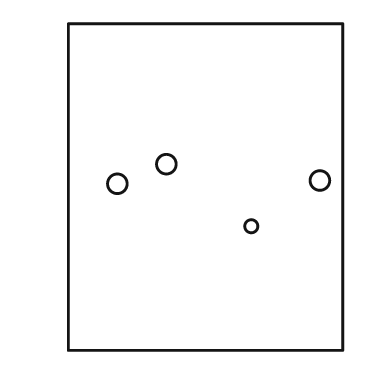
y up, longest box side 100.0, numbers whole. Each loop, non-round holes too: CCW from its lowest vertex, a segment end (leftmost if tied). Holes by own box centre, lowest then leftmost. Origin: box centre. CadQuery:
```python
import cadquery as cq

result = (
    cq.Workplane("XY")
    .moveTo(-42.0, -50.0)
    .lineTo(42.0, -50.0)
    .lineTo(42.0, 50.0)
    .lineTo(-42.0, 50.0)
    .close()
    .moveTo(14.0, -12.0)
    .circle(2.0)
    .moveTo(-27.0, 1.0)
    .circle(3.0)
    .moveTo(35.0, 2.0)
    .circle(3.0)
    .moveTo(-12.0, 7.0)
    .circle(3.0)
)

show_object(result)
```